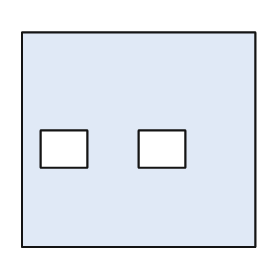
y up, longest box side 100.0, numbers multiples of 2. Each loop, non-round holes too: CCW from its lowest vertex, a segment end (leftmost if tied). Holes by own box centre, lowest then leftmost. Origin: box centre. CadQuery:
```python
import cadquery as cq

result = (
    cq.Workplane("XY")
    .moveTo(-50.0, -46.0)
    .lineTo(50.0, -46.0)
    .lineTo(50.0, 46.0)
    .lineTo(-50.0, 46.0)
    .close()
    .moveTo(-42.0, -12.0)
    .lineTo(-22.0, -12.0)
    .lineTo(-22.0, 4.0)
    .lineTo(-42.0, 4.0)
    .close()
    .moveTo(0.0, -12.0)
    .lineTo(20.0, -12.0)
    .lineTo(20.0, 4.0)
    .lineTo(0.0, 4.0)
    .close()
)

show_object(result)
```